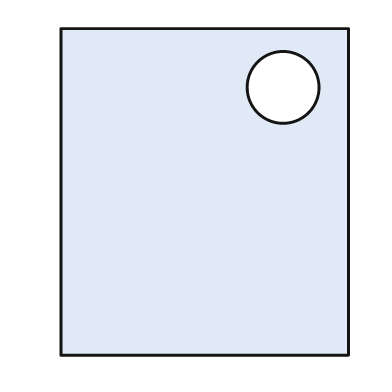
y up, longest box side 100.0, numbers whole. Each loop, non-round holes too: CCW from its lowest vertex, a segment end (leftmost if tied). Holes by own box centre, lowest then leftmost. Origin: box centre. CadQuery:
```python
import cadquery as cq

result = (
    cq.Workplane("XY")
    .moveTo(-44.0, -50.0)
    .lineTo(44.0, -50.0)
    .lineTo(44.0, 50.0)
    .lineTo(-44.0, 50.0)
    .close()
    .moveTo(24.0, 32.0)
    .circle(11.0)
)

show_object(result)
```